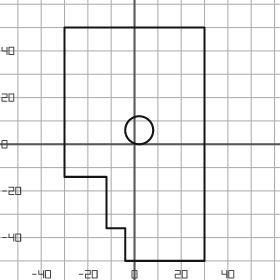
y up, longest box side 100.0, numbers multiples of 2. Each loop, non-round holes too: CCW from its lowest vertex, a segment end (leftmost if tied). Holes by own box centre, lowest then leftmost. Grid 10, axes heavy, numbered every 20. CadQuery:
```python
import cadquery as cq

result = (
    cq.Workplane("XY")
    .moveTo(-4.0, -50.0)
    .lineTo(30.0, -50.0)
    .lineTo(30.0, 50.0)
    .lineTo(-30.0, 50.0)
    .lineTo(-30.0, -14.0)
    .lineTo(-12.0, -14.0)
    .lineTo(-12.0, -36.0)
    .lineTo(-4.0, -36.0)
    .close()
    .moveTo(2.0, 6.0)
    .circle(6.0)
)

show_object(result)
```